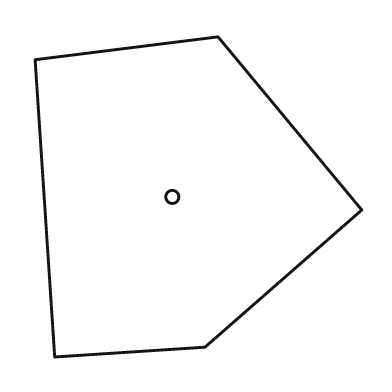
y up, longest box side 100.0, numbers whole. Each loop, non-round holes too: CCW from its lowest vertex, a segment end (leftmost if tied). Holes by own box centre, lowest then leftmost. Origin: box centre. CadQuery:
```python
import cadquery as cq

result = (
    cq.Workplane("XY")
    .moveTo(-44.0, -49.0)
    .lineTo(2.0, -46.0)
    .lineTo(50.0, -4.0)
    .lineTo(6.0, 49.0)
    .lineTo(-50.0, 42.0)
    .close()
    .moveTo(-8.0, 0.0)
    .circle(2.0)
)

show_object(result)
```